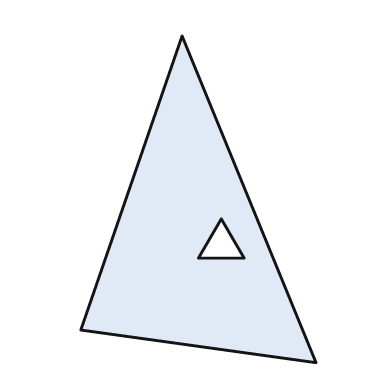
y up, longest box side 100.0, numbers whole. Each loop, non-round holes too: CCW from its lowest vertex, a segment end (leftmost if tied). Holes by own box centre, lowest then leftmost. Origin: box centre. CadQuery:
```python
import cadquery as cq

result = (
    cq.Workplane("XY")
    .moveTo(36.0, -50.0)
    .lineTo(-5.0, 50.0)
    .lineTo(-36.0, -40.0)
    .close()
    .moveTo(0.0, -18.0)
    .lineTo(14.0, -18.0)
    .lineTo(7.0, -6.0)
    .close()
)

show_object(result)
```